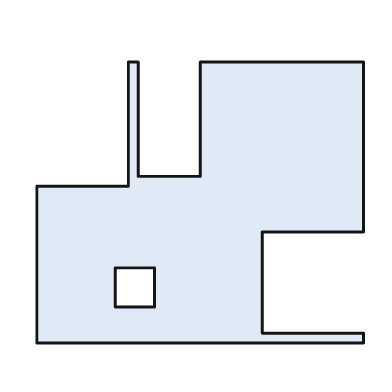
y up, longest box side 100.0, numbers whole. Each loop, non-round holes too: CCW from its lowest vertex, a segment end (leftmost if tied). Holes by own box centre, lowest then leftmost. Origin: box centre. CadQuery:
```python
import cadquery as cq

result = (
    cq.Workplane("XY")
    .moveTo(-50.0, -43.0)
    .lineTo(50.0, -43.0)
    .lineTo(50.0, -40.0)
    .lineTo(19.0, -40.0)
    .lineTo(19.0, -9.0)
    .lineTo(50.0, -9.0)
    .lineTo(50.0, 43.0)
    .lineTo(0.0, 43.0)
    .lineTo(0.0, 8.0)
    .lineTo(-19.0, 8.0)
    .lineTo(-19.0, 43.0)
    .lineTo(-22.0, 43.0)
    .lineTo(-22.0, 5.0)
    .lineTo(-50.0, 5.0)
    .close()
    .moveTo(-26.0, -32.0)
    .lineTo(-14.0, -32.0)
    .lineTo(-14.0, -20.0)
    .lineTo(-26.0, -20.0)
    .close()
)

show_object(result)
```